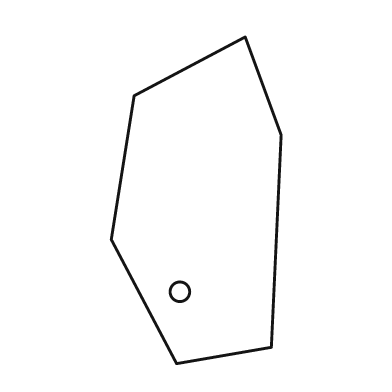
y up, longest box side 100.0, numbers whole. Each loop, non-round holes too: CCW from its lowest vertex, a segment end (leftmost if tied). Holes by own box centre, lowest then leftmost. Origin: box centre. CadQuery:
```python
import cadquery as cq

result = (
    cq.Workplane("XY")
    .moveTo(-6.0, -50.0)
    .lineTo(23.0, -45.0)
    .lineTo(26.0, 20.0)
    .lineTo(15.0, 50.0)
    .lineTo(-19.0, 32.0)
    .lineTo(-26.0, -12.0)
    .close()
    .moveTo(-5.0, -28.0)
    .circle(3.0)
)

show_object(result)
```